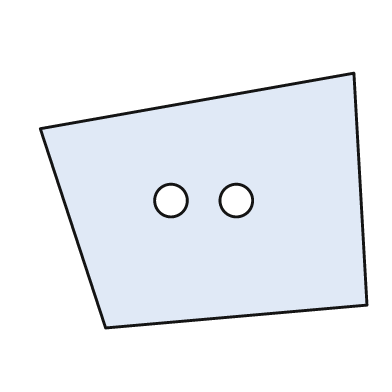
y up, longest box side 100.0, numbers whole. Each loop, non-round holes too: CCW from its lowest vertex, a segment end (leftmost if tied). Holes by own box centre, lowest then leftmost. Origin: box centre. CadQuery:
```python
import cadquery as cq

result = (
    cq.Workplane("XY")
    .moveTo(-30.0, -39.0)
    .lineTo(50.0, -32.0)
    .lineTo(46.0, 39.0)
    .lineTo(-50.0, 22.0)
    .close()
    .moveTo(-10.0, 0.0)
    .circle(5.0)
    .moveTo(10.0, 0.0)
    .circle(5.0)
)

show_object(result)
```